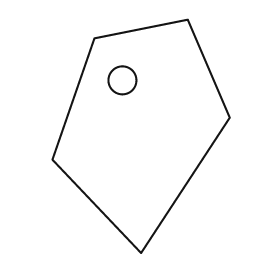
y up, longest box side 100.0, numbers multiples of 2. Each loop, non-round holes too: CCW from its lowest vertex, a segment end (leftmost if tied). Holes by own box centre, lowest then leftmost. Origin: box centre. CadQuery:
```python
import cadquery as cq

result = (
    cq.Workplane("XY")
    .moveTo(0.0, -50.0)
    .lineTo(38.0, 8.0)
    .lineTo(20.0, 50.0)
    .lineTo(-20.0, 42.0)
    .lineTo(-38.0, -10.0)
    .close()
    .moveTo(-8.0, 24.0)
    .circle(6.0)
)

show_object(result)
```